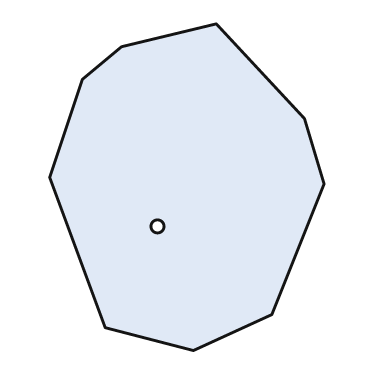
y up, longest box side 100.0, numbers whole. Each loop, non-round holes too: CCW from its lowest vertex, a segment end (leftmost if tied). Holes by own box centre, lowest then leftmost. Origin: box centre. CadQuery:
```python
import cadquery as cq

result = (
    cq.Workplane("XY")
    .moveTo(2.0, -50.0)
    .lineTo(26.0, -39.0)
    .lineTo(42.0, 1.0)
    .lineTo(36.0, 21.0)
    .lineTo(9.0, 50.0)
    .lineTo(-20.0, 43.0)
    .lineTo(-32.0, 33.0)
    .lineTo(-42.0, 3.0)
    .lineTo(-25.0, -43.0)
    .close()
    .moveTo(-9.0, -12.0)
    .circle(2.0)
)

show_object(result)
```